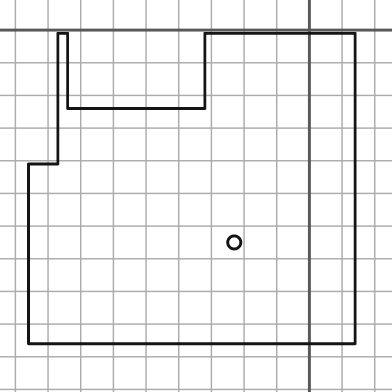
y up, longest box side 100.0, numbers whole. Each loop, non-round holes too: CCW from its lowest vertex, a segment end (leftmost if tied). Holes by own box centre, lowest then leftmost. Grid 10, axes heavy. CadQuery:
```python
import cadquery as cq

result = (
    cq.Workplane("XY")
    .moveTo(-86.0, -96.0)
    .lineTo(14.0, -96.0)
    .lineTo(14.0, -1.0)
    .lineTo(-32.0, -1.0)
    .lineTo(-32.0, -24.0)
    .lineTo(-74.0, -24.0)
    .lineTo(-74.0, -1.0)
    .lineTo(-77.0, -1.0)
    .lineTo(-77.0, -41.0)
    .lineTo(-86.0, -41.0)
    .close()
    .moveTo(-23.0, -65.0)
    .circle(2.0)
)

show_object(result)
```